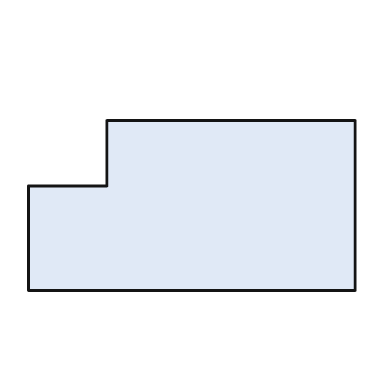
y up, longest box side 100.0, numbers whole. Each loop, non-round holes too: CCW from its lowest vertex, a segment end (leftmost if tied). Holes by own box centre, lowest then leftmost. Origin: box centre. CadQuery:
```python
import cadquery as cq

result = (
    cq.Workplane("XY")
    .moveTo(-50.0, -26.0)
    .lineTo(50.0, -26.0)
    .lineTo(50.0, 26.0)
    .lineTo(-26.0, 26.0)
    .lineTo(-26.0, 6.0)
    .lineTo(-50.0, 6.0)
    .close()
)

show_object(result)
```